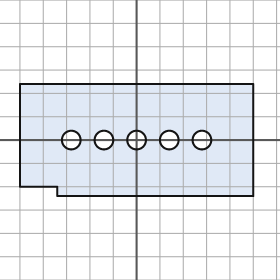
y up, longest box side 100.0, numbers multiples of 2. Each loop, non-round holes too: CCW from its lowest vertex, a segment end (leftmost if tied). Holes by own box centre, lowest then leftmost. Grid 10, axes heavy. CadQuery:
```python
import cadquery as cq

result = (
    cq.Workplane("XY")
    .moveTo(-34.0, -24.0)
    .lineTo(50.0, -24.0)
    .lineTo(50.0, 24.0)
    .lineTo(-50.0, 24.0)
    .lineTo(-50.0, -20.0)
    .lineTo(-34.0, -20.0)
    .close()
    .moveTo(-28.0, 0.0)
    .circle(4.0)
    .moveTo(-14.0, 0.0)
    .circle(4.0)
    .moveTo(0.0, 0.0)
    .circle(4.0)
    .moveTo(14.0, 0.0)
    .circle(4.0)
    .moveTo(28.0, 0.0)
    .circle(4.0)
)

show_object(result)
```